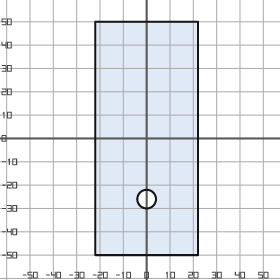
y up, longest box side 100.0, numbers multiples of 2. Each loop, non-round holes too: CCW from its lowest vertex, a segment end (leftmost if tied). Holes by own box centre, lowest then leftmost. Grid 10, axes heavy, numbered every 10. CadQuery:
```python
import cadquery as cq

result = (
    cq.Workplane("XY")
    .moveTo(-22.0, -50.0)
    .lineTo(22.0, -50.0)
    .lineTo(22.0, 50.0)
    .lineTo(-22.0, 50.0)
    .close()
    .moveTo(0.0, -26.0)
    .circle(4.0)
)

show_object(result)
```